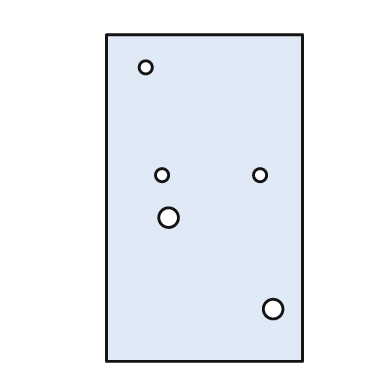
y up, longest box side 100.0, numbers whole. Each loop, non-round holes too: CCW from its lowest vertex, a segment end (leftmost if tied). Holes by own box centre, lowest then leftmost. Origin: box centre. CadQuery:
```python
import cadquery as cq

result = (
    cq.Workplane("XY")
    .moveTo(-30.0, -50.0)
    .lineTo(30.0, -50.0)
    .lineTo(30.0, 50.0)
    .lineTo(-30.0, 50.0)
    .close()
    .moveTo(21.0, -34.0)
    .circle(3.0)
    .moveTo(-11.0, -6.0)
    .circle(3.0)
    .moveTo(-13.0, 7.0)
    .circle(2.0)
    .moveTo(17.0, 7.0)
    .circle(2.0)
    .moveTo(-18.0, 40.0)
    .circle(2.0)
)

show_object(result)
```